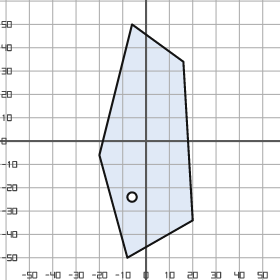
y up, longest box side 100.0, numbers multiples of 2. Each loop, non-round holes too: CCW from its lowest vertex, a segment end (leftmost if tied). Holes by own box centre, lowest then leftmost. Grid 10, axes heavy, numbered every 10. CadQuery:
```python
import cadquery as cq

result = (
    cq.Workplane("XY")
    .moveTo(-8.0, -50.0)
    .lineTo(20.0, -34.0)
    .lineTo(16.0, 34.0)
    .lineTo(-6.0, 50.0)
    .lineTo(-20.0, -6.0)
    .close()
    .moveTo(-6.0, -24.0)
    .circle(2.0)
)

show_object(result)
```